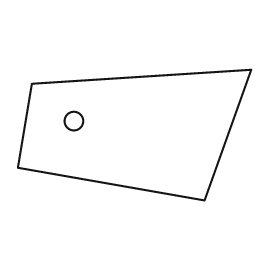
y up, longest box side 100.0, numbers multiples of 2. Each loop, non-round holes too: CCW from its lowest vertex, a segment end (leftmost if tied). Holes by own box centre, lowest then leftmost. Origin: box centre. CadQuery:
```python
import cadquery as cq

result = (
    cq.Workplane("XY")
    .moveTo(30.0, -28.0)
    .lineTo(50.0, 28.0)
    .lineTo(-44.0, 22.0)
    .lineTo(-50.0, -14.0)
    .close()
    .moveTo(-26.0, 6.0)
    .circle(4.0)
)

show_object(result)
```